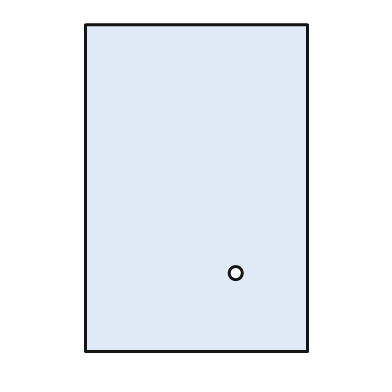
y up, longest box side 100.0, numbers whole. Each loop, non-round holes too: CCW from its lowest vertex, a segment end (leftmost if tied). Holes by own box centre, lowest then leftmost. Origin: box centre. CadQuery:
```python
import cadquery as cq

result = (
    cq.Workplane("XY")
    .moveTo(-34.0, -50.0)
    .lineTo(34.0, -50.0)
    .lineTo(34.0, 50.0)
    .lineTo(-34.0, 50.0)
    .close()
    .moveTo(12.0, -26.0)
    .circle(2.0)
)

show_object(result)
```